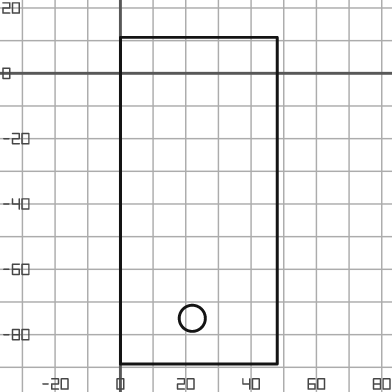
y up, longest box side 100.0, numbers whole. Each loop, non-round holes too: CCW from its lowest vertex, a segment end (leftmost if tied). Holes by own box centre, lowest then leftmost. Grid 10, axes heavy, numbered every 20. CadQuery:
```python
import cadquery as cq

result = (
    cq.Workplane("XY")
    .moveTo(0.0, -89.0)
    .lineTo(48.0, -89.0)
    .lineTo(48.0, 11.0)
    .lineTo(0.0, 11.0)
    .close()
    .moveTo(22.0, -75.0)
    .circle(4.0)
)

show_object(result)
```